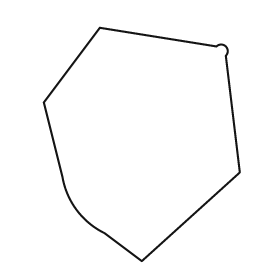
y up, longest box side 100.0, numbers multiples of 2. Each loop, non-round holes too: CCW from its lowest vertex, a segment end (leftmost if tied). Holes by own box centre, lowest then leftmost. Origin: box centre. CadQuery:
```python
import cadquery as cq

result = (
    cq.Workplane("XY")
    .moveTo(0.0, -50.0)
    .lineTo(42.0, -12.0)
    .lineTo(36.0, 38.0)
    .threePointArc((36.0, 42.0), (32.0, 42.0))
    .lineTo(-18.0, 50.0)
    .lineTo(-42.0, 18.0)
    .lineTo(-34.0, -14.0)
    .threePointArc((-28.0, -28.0), (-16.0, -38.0))
    .close()
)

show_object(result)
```